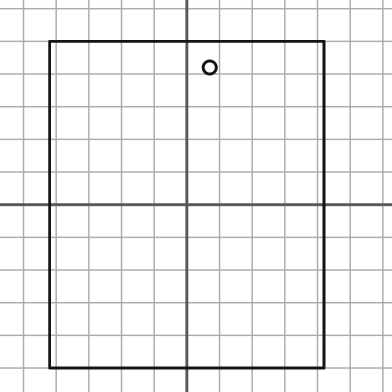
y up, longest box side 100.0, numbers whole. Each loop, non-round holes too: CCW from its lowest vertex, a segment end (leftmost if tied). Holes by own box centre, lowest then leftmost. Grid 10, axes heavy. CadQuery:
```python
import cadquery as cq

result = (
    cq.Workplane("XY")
    .moveTo(-42.0, -50.0)
    .lineTo(42.0, -50.0)
    .lineTo(42.0, 50.0)
    .lineTo(-42.0, 50.0)
    .close()
    .moveTo(7.0, 42.0)
    .circle(2.0)
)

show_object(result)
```